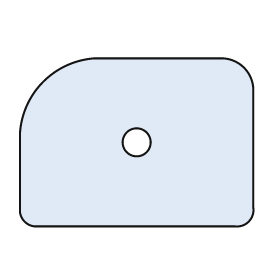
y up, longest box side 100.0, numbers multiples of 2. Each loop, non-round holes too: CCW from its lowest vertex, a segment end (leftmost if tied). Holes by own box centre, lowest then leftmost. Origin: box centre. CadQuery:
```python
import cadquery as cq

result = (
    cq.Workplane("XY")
    .moveTo(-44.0, -36.0)
    .lineTo(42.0, -36.0)
    .threePointArc((48.0, -34.0), (50.0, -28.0))
    .lineTo(50.0, 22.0)
    .threePointArc((46.0, 32.0), (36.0, 36.0))
    .lineTo(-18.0, 36.0)
    .threePointArc((-40.0, 26.0), (-50.0, 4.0))
    .lineTo(-50.0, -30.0)
    .threePointArc((-48.0, -34.0), (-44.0, -36.0))
    .close()
    .moveTo(0.0, 0.0)
    .circle(6.0)
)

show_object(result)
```